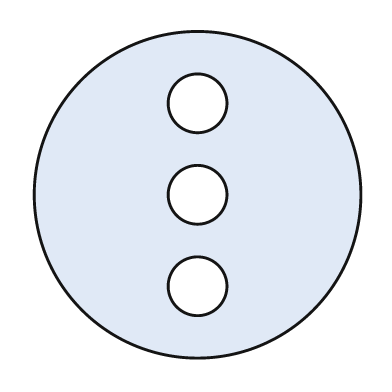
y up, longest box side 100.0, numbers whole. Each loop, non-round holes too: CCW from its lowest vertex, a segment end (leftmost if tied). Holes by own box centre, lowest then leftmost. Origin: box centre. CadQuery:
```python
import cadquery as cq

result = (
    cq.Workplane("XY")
    .moveTo(0.0, 0.0)
    .circle(50.0)
    .moveTo(0.0, -28.0)
    .circle(9.0)
    .moveTo(0.0, 0.0)
    .circle(9.0)
    .moveTo(0.0, 28.0)
    .circle(9.0)
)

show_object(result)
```